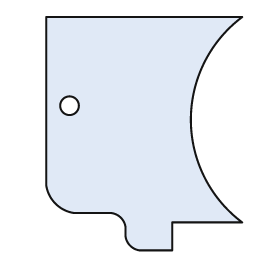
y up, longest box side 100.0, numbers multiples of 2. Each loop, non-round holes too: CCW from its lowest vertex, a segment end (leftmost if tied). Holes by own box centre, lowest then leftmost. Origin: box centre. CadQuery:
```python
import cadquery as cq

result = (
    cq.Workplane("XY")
    .moveTo(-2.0, -50.0)
    .lineTo(12.0, -50.0)
    .lineTo(12.0, -38.0)
    .lineTo(42.0, -38.0)
    .threePointArc((20.0, 6.0), (42.0, 50.0))
    .lineTo(-42.0, 50.0)
    .lineTo(-42.0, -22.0)
    .threePointArc((-38.0, -30.0), (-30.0, -34.0))
    .lineTo(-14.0, -34.0)
    .threePointArc((-10.0, -36.0), (-8.0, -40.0))
    .lineTo(-8.0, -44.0)
    .threePointArc((-6.0, -48.0), (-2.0, -50.0))
    .close()
    .moveTo(-32.0, 12.0)
    .circle(4.0)
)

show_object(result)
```